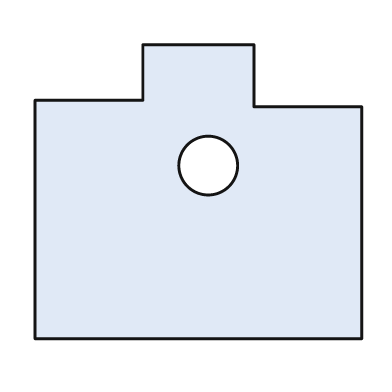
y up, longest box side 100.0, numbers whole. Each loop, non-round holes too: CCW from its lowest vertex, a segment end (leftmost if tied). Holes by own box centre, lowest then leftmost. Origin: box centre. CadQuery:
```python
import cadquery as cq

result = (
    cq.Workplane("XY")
    .moveTo(-50.0, -45.0)
    .lineTo(50.0, -45.0)
    .lineTo(50.0, 26.0)
    .lineTo(17.0, 26.0)
    .lineTo(17.0, 45.0)
    .lineTo(-17.0, 45.0)
    .lineTo(-17.0, 28.0)
    .lineTo(-50.0, 28.0)
    .close()
    .moveTo(3.0, 8.0)
    .circle(9.0)
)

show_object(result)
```